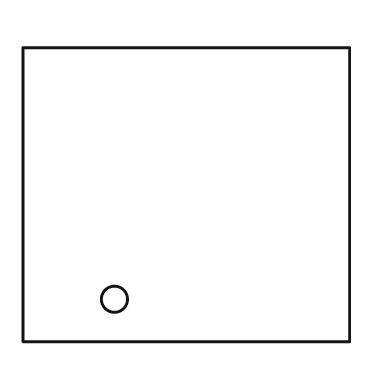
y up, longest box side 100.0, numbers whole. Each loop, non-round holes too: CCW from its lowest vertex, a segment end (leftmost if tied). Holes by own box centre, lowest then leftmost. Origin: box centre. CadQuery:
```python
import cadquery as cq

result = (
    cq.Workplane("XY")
    .moveTo(-50.0, -45.0)
    .lineTo(50.0, -45.0)
    .lineTo(50.0, 45.0)
    .lineTo(-50.0, 45.0)
    .close()
    .moveTo(-22.0, -32.0)
    .circle(4.0)
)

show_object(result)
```